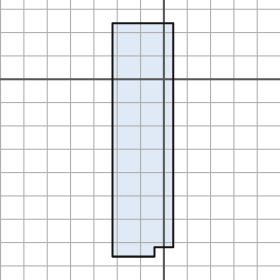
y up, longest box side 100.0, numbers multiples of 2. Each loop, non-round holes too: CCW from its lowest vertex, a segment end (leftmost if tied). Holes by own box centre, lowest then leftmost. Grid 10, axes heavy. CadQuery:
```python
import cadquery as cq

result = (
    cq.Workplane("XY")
    .moveTo(-22.0, -76.0)
    .lineTo(-4.0, -76.0)
    .lineTo(-4.0, -72.0)
    .lineTo(4.0, -72.0)
    .lineTo(4.0, 24.0)
    .lineTo(-22.0, 24.0)
    .close()
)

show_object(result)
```